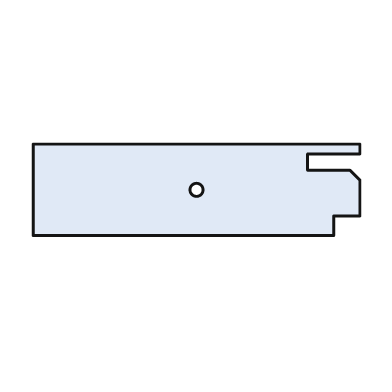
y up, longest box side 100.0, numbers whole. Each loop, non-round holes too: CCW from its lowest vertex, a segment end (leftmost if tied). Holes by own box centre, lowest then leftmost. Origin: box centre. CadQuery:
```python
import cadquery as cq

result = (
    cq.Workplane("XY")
    .moveTo(-50.0, -14.0)
    .lineTo(42.0, -14.0)
    .lineTo(42.0, -8.0)
    .lineTo(50.0, -8.0)
    .lineTo(50.0, 3.0)
    .lineTo(47.0, 6.0)
    .lineTo(34.0, 6.0)
    .lineTo(34.0, 11.0)
    .lineTo(50.0, 11.0)
    .lineTo(50.0, 14.0)
    .lineTo(-50.0, 14.0)
    .close()
    .moveTo(0.0, 0.0)
    .circle(2.0)
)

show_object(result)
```